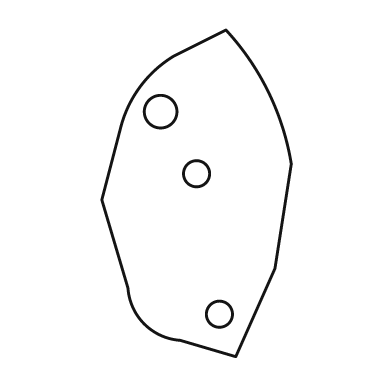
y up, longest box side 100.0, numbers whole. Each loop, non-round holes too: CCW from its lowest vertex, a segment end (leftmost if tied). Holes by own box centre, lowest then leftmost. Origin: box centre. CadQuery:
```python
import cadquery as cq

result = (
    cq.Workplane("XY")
    .moveTo(12.0, -50.0)
    .lineTo(24.0, -23.0)
    .lineTo(29.0, 9.0)
    .threePointArc((22.0, 31.0), (9.0, 50.0))
    .lineTo(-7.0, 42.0)
    .threePointArc((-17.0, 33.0), (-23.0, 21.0))
    .lineTo(-29.0, -2.0)
    .lineTo(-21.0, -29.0)
    .threePointArc((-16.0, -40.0), (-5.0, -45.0))
    .close()
    .moveTo(7.0, -37.0)
    .circle(4.0)
    .moveTo(0.0, 6.0)
    .circle(4.0)
    .moveTo(-11.0, 25.0)
    .circle(5.0)
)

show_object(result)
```